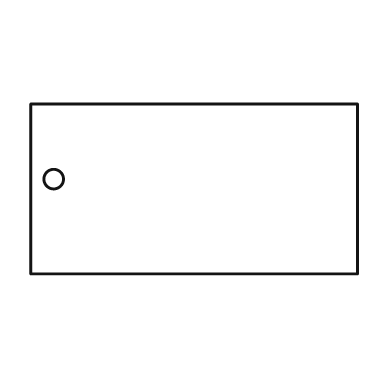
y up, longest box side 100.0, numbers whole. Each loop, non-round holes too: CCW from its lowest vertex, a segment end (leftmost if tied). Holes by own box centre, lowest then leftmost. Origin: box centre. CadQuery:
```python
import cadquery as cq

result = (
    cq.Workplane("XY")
    .moveTo(-50.0, -26.0)
    .lineTo(50.0, -26.0)
    .lineTo(50.0, 26.0)
    .lineTo(-50.0, 26.0)
    .close()
    .moveTo(-43.0, 3.0)
    .circle(3.0)
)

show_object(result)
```